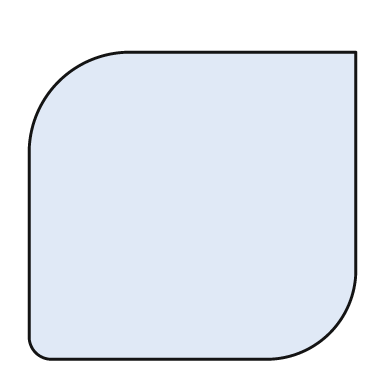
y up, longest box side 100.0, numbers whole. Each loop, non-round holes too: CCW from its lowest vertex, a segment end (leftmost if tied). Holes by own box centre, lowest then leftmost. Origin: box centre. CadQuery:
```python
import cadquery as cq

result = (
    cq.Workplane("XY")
    .moveTo(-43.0, -47.0)
    .lineTo(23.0, -47.0)
    .threePointArc((42.0, -39.0), (50.0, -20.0))
    .lineTo(50.0, 47.0)
    .lineTo(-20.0, 47.0)
    .threePointArc((-41.0, 38.0), (-50.0, 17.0))
    .lineTo(-50.0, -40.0)
    .threePointArc((-48.0, -45.0), (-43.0, -47.0))
    .close()
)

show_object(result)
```